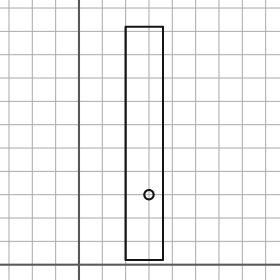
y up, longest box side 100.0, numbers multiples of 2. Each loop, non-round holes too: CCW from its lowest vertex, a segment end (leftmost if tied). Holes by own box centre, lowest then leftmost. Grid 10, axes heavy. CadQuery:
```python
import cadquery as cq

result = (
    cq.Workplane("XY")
    .moveTo(20.0, 2.0)
    .lineTo(36.0, 2.0)
    .lineTo(36.0, 102.0)
    .lineTo(20.0, 102.0)
    .close()
    .moveTo(30.0, 30.0)
    .circle(2.0)
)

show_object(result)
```